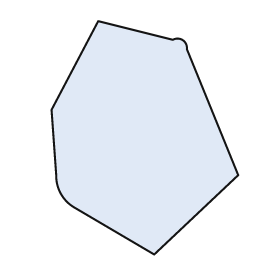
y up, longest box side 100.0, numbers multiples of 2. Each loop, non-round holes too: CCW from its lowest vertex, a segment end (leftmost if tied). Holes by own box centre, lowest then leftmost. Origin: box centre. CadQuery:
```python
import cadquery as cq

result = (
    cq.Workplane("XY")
    .moveTo(4.0, -50.0)
    .lineTo(40.0, -16.0)
    .lineTo(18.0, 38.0)
    .threePointArc((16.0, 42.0), (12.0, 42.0))
    .lineTo(-20.0, 50.0)
    .lineTo(-40.0, 12.0)
    .lineTo(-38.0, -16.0)
    .threePointArc((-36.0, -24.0), (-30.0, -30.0))
    .close()
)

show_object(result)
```